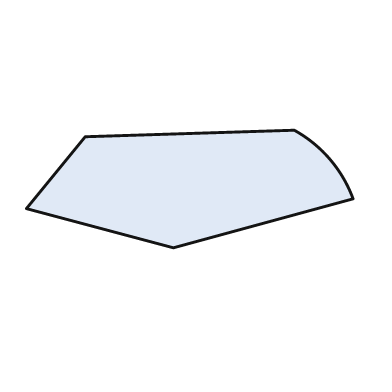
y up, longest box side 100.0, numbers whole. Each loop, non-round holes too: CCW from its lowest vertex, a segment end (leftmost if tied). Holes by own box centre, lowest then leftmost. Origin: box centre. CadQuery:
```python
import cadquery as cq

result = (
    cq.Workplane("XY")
    .moveTo(-5.0, -18.0)
    .lineTo(50.0, -3.0)
    .threePointArc((43.0, 9.0), (32.0, 18.0))
    .lineTo(-32.0, 16.0)
    .lineTo(-50.0, -6.0)
    .close()
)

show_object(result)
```